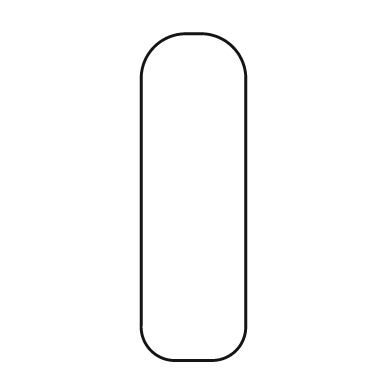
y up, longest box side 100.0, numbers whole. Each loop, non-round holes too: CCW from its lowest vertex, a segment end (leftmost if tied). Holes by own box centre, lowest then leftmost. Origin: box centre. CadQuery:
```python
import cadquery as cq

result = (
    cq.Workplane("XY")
    .moveTo(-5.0, -50.0)
    .lineTo(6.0, -50.0)
    .threePointArc((13.0, -47.0), (16.0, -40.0))
    .lineTo(16.0, 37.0)
    .threePointArc((12.0, 46.0), (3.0, 50.0))
    .lineTo(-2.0, 50.0)
    .threePointArc((-12.0, 46.0), (-16.0, 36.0))
    .lineTo(-16.0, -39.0)
    .threePointArc((-13.0, -47.0), (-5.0, -50.0))
    .close()
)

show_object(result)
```